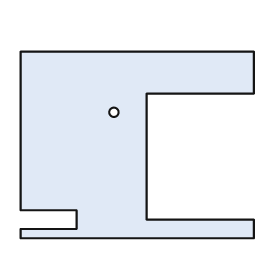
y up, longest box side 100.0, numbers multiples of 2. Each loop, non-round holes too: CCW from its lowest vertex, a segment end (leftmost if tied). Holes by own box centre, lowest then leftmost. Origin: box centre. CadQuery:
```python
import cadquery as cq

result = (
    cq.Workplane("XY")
    .moveTo(-50.0, -40.0)
    .lineTo(50.0, -40.0)
    .lineTo(50.0, -32.0)
    .lineTo(4.0, -32.0)
    .lineTo(4.0, 22.0)
    .lineTo(50.0, 22.0)
    .lineTo(50.0, 40.0)
    .lineTo(-50.0, 40.0)
    .lineTo(-50.0, -28.0)
    .lineTo(-26.0, -28.0)
    .lineTo(-26.0, -36.0)
    .lineTo(-50.0, -36.0)
    .close()
    .moveTo(-10.0, 14.0)
    .circle(2.0)
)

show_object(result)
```